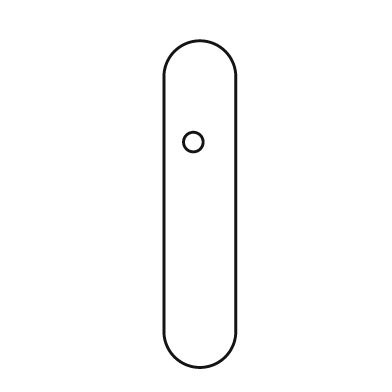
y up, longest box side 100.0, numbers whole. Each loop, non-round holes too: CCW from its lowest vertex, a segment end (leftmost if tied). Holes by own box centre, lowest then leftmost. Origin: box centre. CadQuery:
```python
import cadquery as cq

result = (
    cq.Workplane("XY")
    .moveTo(-11.0, -39.0)
    .threePointArc((0.0, -50.0), (11.0, -39.0))
    .lineTo(11.0, 39.0)
    .threePointArc((0.0, 50.0), (-11.0, 39.0))
    .close()
    .moveTo(-2.0, 19.0)
    .circle(3.0)
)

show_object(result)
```